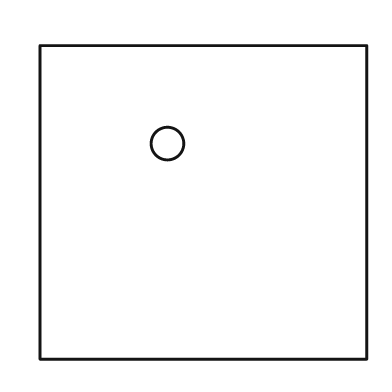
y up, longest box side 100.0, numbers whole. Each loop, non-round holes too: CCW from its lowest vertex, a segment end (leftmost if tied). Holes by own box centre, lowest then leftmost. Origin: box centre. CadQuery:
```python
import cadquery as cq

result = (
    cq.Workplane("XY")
    .moveTo(-50.0, -48.0)
    .lineTo(50.0, -48.0)
    .lineTo(50.0, 48.0)
    .lineTo(-50.0, 48.0)
    .close()
    .moveTo(-11.0, 18.0)
    .circle(5.0)
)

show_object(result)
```